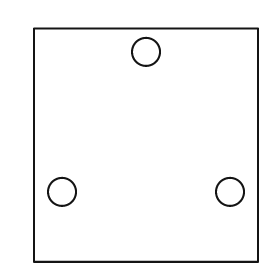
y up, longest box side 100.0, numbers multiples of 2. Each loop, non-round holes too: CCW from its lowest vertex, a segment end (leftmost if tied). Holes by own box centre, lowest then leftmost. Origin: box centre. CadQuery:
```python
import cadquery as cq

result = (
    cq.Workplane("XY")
    .moveTo(-48.0, -50.0)
    .lineTo(48.0, -50.0)
    .lineTo(48.0, 50.0)
    .lineTo(-48.0, 50.0)
    .close()
    .moveTo(-36.0, -20.0)
    .circle(6.0)
    .moveTo(36.0, -20.0)
    .circle(6.0)
    .moveTo(0.0, 40.0)
    .circle(6.0)
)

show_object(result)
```